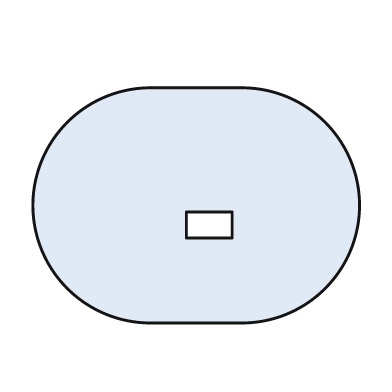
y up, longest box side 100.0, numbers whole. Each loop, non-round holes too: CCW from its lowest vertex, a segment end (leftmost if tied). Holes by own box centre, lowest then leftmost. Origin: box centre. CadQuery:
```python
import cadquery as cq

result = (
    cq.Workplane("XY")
    .moveTo(-14.0, -36.0)
    .lineTo(14.0, -36.0)
    .threePointArc((50.0, 0.0), (14.0, 36.0))
    .lineTo(-14.0, 36.0)
    .threePointArc((-50.0, 0.0), (-14.0, -36.0))
    .close()
    .moveTo(-3.0, -10.0)
    .lineTo(11.0, -10.0)
    .lineTo(11.0, -2.0)
    .lineTo(-3.0, -2.0)
    .close()
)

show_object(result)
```